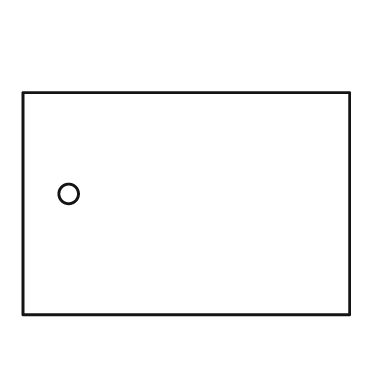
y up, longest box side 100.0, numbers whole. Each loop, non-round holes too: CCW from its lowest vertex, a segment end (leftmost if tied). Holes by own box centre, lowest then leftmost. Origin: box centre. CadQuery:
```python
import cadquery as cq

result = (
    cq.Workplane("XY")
    .moveTo(-50.0, -34.0)
    .lineTo(50.0, -34.0)
    .lineTo(50.0, 34.0)
    .lineTo(-50.0, 34.0)
    .close()
    .moveTo(-36.0, 3.0)
    .circle(3.0)
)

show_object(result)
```